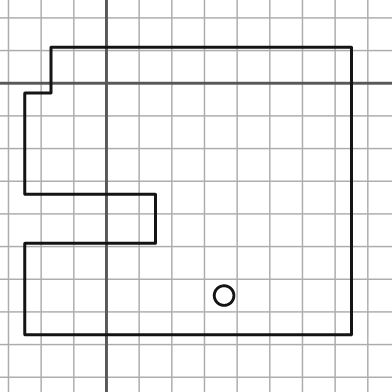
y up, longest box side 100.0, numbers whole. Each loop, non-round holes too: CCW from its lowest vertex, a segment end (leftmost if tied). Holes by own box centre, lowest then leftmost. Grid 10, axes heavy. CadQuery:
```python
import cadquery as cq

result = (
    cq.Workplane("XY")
    .moveTo(-25.0, -77.0)
    .lineTo(75.0, -77.0)
    .lineTo(75.0, 11.0)
    .lineTo(-17.0, 11.0)
    .lineTo(-17.0, -3.0)
    .lineTo(-25.0, -3.0)
    .lineTo(-25.0, -34.0)
    .lineTo(15.0, -34.0)
    .lineTo(15.0, -49.0)
    .lineTo(-25.0, -49.0)
    .close()
    .moveTo(36.0, -65.0)
    .circle(3.0)
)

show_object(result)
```